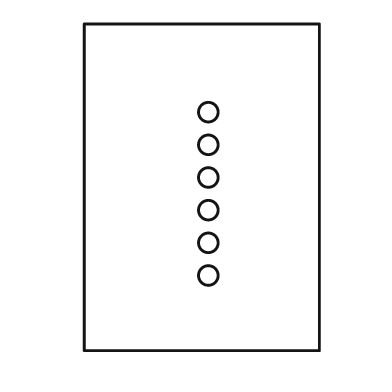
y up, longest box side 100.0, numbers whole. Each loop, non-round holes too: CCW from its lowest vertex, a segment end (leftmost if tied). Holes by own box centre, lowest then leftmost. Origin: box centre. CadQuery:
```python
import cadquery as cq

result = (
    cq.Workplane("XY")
    .moveTo(-36.0, -50.0)
    .lineTo(36.0, -50.0)
    .lineTo(36.0, 50.0)
    .lineTo(-36.0, 50.0)
    .close()
    .moveTo(2.0, -27.0)
    .circle(3.0)
    .moveTo(2.0, -17.0)
    .circle(3.0)
    .moveTo(2.0, -7.0)
    .circle(3.0)
    .moveTo(2.0, 3.0)
    .circle(3.0)
    .moveTo(2.0, 13.0)
    .circle(3.0)
    .moveTo(2.0, 23.0)
    .circle(3.0)
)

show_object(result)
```